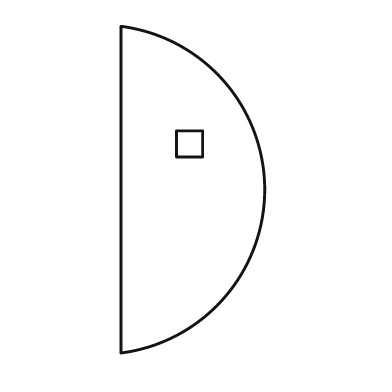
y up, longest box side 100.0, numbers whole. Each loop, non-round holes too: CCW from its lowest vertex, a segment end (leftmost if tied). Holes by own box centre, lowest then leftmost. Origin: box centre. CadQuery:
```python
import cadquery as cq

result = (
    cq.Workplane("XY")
    .moveTo(-22.0, -50.0)
    .threePointArc((22.0, 0.0), (-22.0, 50.0))
    .close()
    .moveTo(-5.0, 10.0)
    .lineTo(3.0, 10.0)
    .lineTo(3.0, 18.0)
    .lineTo(-5.0, 18.0)
    .close()
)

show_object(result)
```